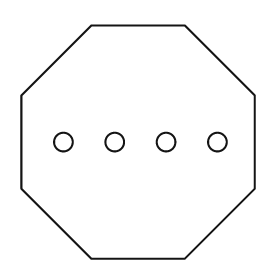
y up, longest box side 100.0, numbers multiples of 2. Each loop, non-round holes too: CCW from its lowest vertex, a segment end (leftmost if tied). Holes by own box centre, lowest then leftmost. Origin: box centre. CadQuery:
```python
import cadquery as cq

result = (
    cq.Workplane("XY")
    .moveTo(-20.0, -50.0)
    .lineTo(20.0, -50.0)
    .lineTo(50.0, -20.0)
    .lineTo(50.0, 20.0)
    .lineTo(20.0, 50.0)
    .lineTo(-20.0, 50.0)
    .lineTo(-50.0, 20.0)
    .lineTo(-50.0, -20.0)
    .close()
    .moveTo(-32.0, 0.0)
    .circle(4.0)
    .moveTo(-10.0, 0.0)
    .circle(4.0)
    .moveTo(12.0, 0.0)
    .circle(4.0)
    .moveTo(34.0, 0.0)
    .circle(4.0)
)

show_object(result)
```